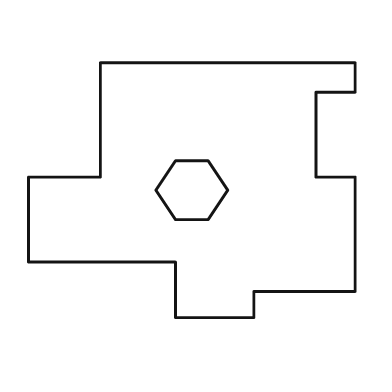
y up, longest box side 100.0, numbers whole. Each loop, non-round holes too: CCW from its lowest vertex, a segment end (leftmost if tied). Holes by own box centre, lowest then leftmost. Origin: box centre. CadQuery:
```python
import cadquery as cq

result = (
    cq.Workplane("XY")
    .moveTo(-5.0, -39.0)
    .lineTo(19.0, -39.0)
    .lineTo(19.0, -31.0)
    .lineTo(50.0, -31.0)
    .lineTo(50.0, 4.0)
    .lineTo(38.0, 4.0)
    .lineTo(38.0, 30.0)
    .lineTo(50.0, 30.0)
    .lineTo(50.0, 39.0)
    .lineTo(-28.0, 39.0)
    .lineTo(-28.0, 4.0)
    .lineTo(-50.0, 4.0)
    .lineTo(-50.0, -22.0)
    .lineTo(-5.0, -22.0)
    .close()
    .moveTo(-5.0, -9.0)
    .lineTo(5.0, -9.0)
    .lineTo(11.0, 0.0)
    .lineTo(5.0, 9.0)
    .lineTo(-5.0, 9.0)
    .lineTo(-11.0, 0.0)
    .close()
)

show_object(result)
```